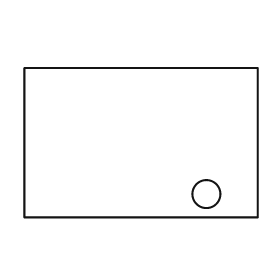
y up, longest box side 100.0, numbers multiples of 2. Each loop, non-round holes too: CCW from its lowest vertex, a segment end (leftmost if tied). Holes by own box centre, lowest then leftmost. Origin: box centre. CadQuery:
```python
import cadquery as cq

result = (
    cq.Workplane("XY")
    .moveTo(-50.0, -32.0)
    .lineTo(50.0, -32.0)
    .lineTo(50.0, 32.0)
    .lineTo(-50.0, 32.0)
    .close()
    .moveTo(28.0, -22.0)
    .circle(6.0)
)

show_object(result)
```